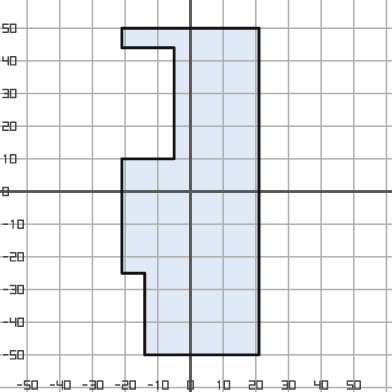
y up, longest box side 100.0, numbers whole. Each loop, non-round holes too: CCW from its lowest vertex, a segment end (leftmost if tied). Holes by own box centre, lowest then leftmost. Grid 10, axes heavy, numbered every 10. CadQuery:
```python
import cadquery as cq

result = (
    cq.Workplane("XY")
    .moveTo(-14.0, -50.0)
    .lineTo(21.0, -50.0)
    .lineTo(21.0, 50.0)
    .lineTo(-21.0, 50.0)
    .lineTo(-21.0, 44.0)
    .lineTo(-5.0, 44.0)
    .lineTo(-5.0, 10.0)
    .lineTo(-21.0, 10.0)
    .lineTo(-21.0, -25.0)
    .lineTo(-14.0, -25.0)
    .close()
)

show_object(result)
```